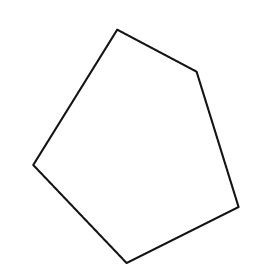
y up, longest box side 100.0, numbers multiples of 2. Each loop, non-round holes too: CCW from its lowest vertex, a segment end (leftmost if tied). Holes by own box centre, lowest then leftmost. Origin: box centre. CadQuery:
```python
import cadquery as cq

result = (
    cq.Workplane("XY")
    .moveTo(-4.0, -50.0)
    .lineTo(44.0, -26.0)
    .lineTo(26.0, 32.0)
    .lineTo(-8.0, 50.0)
    .lineTo(-44.0, -8.0)
    .close()
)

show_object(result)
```